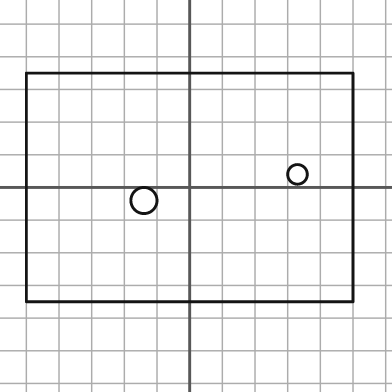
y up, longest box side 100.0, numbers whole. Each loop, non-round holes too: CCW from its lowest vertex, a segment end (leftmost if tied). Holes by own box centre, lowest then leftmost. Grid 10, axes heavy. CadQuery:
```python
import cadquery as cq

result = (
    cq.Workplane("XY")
    .moveTo(-50.0, -35.0)
    .lineTo(50.0, -35.0)
    .lineTo(50.0, 35.0)
    .lineTo(-50.0, 35.0)
    .close()
    .moveTo(-14.0, -4.0)
    .circle(4.0)
    .moveTo(33.0, 4.0)
    .circle(3.0)
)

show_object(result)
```